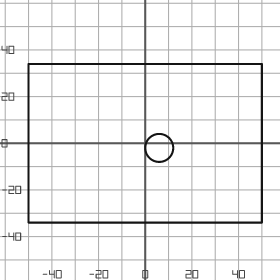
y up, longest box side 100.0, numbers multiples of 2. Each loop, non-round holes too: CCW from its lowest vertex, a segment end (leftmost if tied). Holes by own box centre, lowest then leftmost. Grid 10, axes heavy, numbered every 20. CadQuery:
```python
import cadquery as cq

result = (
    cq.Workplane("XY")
    .moveTo(-50.0, -34.0)
    .lineTo(50.0, -34.0)
    .lineTo(50.0, 34.0)
    .lineTo(-50.0, 34.0)
    .close()
    .moveTo(6.0, -2.0)
    .circle(6.0)
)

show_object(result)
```